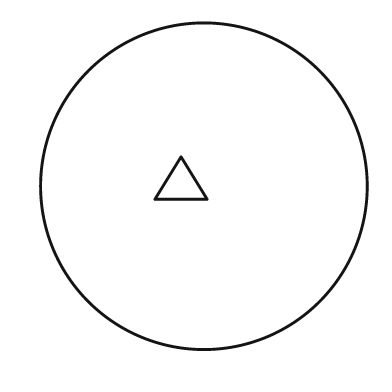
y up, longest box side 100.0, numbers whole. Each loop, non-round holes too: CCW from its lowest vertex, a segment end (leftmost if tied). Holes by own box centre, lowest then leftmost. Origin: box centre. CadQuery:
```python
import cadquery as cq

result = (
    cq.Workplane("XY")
    .moveTo(0.0, 0.0)
    .circle(50.0)
    .moveTo(-15.0, -4.0)
    .lineTo(1.0, -4.0)
    .lineTo(-7.0, 9.0)
    .close()
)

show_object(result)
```